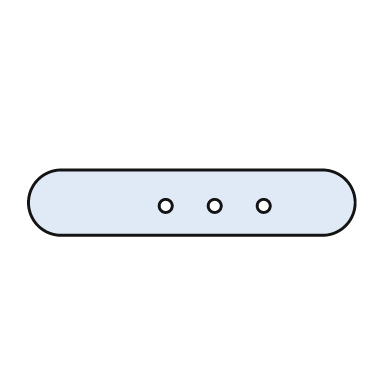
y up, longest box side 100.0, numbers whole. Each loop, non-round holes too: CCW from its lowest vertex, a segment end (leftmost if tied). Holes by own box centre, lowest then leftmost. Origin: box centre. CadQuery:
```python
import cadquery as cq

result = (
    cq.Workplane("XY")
    .moveTo(-40.0, -10.0)
    .lineTo(40.0, -10.0)
    .threePointArc((50.0, 0.0), (40.0, 10.0))
    .lineTo(-40.0, 10.0)
    .threePointArc((-50.0, 0.0), (-40.0, -10.0))
    .close()
    .moveTo(-8.0, -1.0)
    .circle(2.0)
    .moveTo(7.0, -1.0)
    .circle(2.0)
    .moveTo(22.0, -1.0)
    .circle(2.0)
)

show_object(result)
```